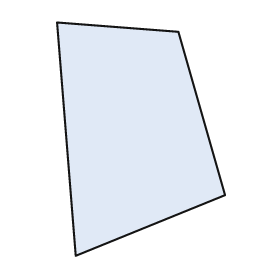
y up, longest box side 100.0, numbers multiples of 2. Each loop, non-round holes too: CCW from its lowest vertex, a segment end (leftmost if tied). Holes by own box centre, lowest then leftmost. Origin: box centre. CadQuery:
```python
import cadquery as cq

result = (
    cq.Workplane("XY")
    .moveTo(-28.0, -50.0)
    .lineTo(36.0, -24.0)
    .lineTo(16.0, 46.0)
    .lineTo(-36.0, 50.0)
    .close()
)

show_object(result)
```